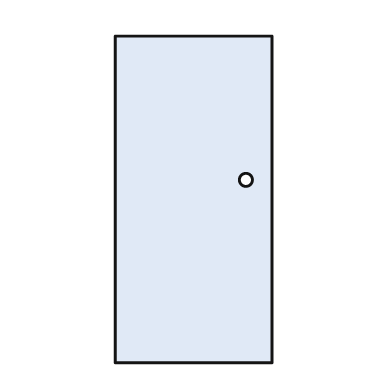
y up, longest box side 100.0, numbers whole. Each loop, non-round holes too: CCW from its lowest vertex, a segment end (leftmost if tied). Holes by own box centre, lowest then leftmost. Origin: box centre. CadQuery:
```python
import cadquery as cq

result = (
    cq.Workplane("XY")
    .moveTo(-24.0, -50.0)
    .lineTo(24.0, -50.0)
    .lineTo(24.0, 50.0)
    .lineTo(-24.0, 50.0)
    .close()
    .moveTo(16.0, 6.0)
    .circle(2.0)
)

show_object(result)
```